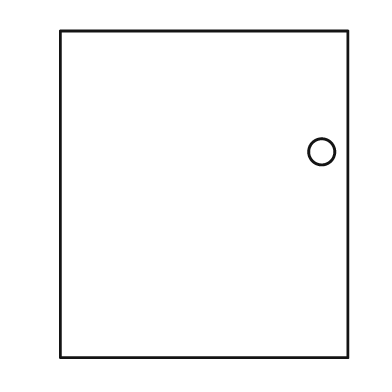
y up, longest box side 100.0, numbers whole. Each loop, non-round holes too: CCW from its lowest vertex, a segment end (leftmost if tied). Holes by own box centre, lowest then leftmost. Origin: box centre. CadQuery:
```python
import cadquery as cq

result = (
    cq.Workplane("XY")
    .moveTo(-44.0, -50.0)
    .lineTo(44.0, -50.0)
    .lineTo(44.0, 50.0)
    .lineTo(-44.0, 50.0)
    .close()
    .moveTo(36.0, 13.0)
    .circle(4.0)
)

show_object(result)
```